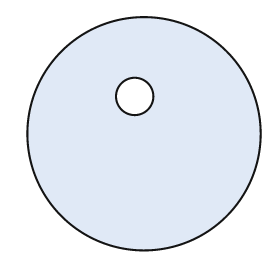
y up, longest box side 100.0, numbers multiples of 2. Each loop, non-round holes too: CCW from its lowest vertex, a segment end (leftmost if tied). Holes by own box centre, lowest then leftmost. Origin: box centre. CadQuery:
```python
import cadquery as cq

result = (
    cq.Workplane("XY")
    .moveTo(0.0, 0.0)
    .circle(50.0)
    .moveTo(-4.0, 16.0)
    .circle(8.0)
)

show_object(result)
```